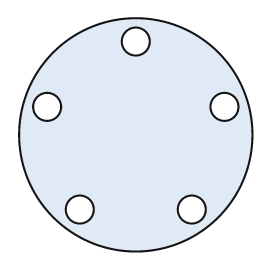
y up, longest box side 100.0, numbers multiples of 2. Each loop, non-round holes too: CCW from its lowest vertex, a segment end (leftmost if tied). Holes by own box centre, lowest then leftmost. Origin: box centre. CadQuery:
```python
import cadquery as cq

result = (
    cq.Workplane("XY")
    .moveTo(0.0, 0.0)
    .circle(50.0)
    .moveTo(-24.0, -32.0)
    .circle(6.0)
    .moveTo(24.0, -32.0)
    .circle(6.0)
    .moveTo(-38.0, 12.0)
    .circle(6.0)
    .moveTo(38.0, 12.0)
    .circle(6.0)
    .moveTo(0.0, 40.0)
    .circle(6.0)
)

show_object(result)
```